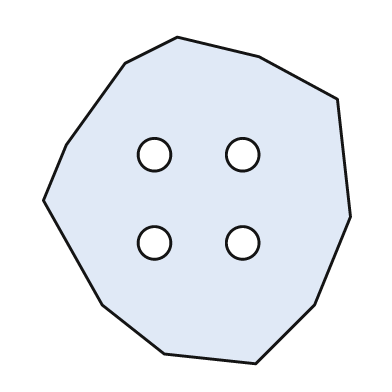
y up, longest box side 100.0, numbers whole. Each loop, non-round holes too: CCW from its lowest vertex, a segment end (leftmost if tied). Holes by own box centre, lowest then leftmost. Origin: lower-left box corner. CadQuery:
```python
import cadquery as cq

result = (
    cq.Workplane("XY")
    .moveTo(65.0, 0.0)
    .lineTo(83.0, 18.0)
    .lineTo(94.0, 45.0)
    .lineTo(90.0, 81.0)
    .lineTo(66.0, 94.0)
    .lineTo(41.0, 100.0)
    .lineTo(25.0, 92.0)
    .lineTo(7.0, 67.0)
    .lineTo(0.0, 50.0)
    .lineTo(18.0, 18.0)
    .lineTo(37.0, 3.0)
    .close()
    .moveTo(34.0, 37.0)
    .circle(5.0)
    .moveTo(61.0, 37.0)
    .circle(5.0)
    .moveTo(34.0, 64.0)
    .circle(5.0)
    .moveTo(61.0, 64.0)
    .circle(5.0)
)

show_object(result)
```